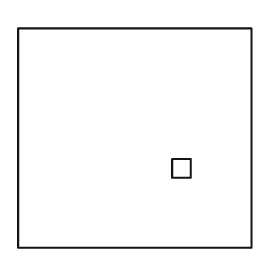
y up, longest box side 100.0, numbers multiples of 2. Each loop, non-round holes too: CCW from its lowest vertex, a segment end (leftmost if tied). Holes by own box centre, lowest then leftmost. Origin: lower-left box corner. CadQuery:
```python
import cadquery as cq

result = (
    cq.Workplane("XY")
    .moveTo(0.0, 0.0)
    .lineTo(100.0, 0.0)
    .lineTo(100.0, 94.0)
    .lineTo(0.0, 94.0)
    .close()
    .moveTo(66.0, 30.0)
    .lineTo(74.0, 30.0)
    .lineTo(74.0, 38.0)
    .lineTo(66.0, 38.0)
    .close()
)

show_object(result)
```